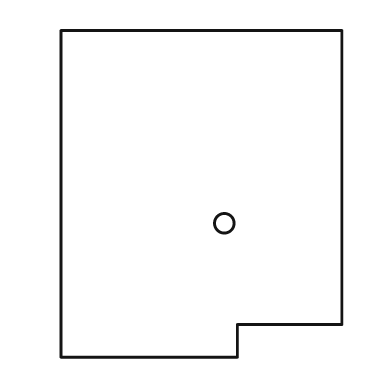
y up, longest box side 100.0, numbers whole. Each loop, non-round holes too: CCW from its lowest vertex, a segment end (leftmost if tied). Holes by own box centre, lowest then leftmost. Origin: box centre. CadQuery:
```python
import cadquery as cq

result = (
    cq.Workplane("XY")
    .moveTo(-43.0, -50.0)
    .lineTo(11.0, -50.0)
    .lineTo(11.0, -40.0)
    .lineTo(43.0, -40.0)
    .lineTo(43.0, 50.0)
    .lineTo(-43.0, 50.0)
    .close()
    .moveTo(7.0, -9.0)
    .circle(3.0)
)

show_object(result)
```